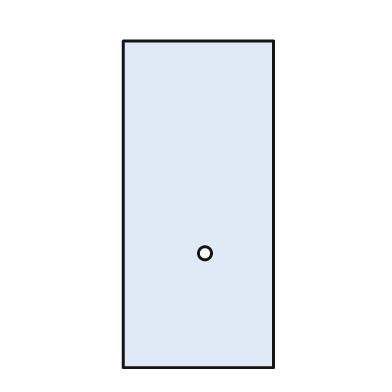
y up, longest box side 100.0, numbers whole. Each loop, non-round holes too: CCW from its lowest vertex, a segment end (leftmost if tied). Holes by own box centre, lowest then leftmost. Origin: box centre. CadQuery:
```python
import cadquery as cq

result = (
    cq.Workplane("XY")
    .moveTo(-23.0, -50.0)
    .lineTo(23.0, -50.0)
    .lineTo(23.0, 50.0)
    .lineTo(-23.0, 50.0)
    .close()
    .moveTo(2.0, -15.0)
    .circle(2.0)
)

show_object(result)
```